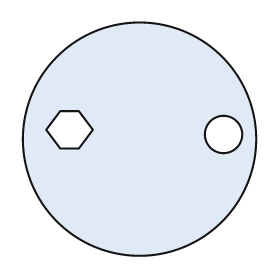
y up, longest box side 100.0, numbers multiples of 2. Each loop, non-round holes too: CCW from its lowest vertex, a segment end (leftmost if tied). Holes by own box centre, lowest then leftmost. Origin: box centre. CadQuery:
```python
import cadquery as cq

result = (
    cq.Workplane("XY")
    .moveTo(0.0, 0.0)
    .circle(50.0)
    .moveTo(36.0, 2.0)
    .circle(8.0)
    .moveTo(-34.0, -4.0)
    .lineTo(-26.0, -4.0)
    .lineTo(-20.0, 4.0)
    .lineTo(-26.0, 12.0)
    .lineTo(-34.0, 12.0)
    .lineTo(-40.0, 4.0)
    .close()
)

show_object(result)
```